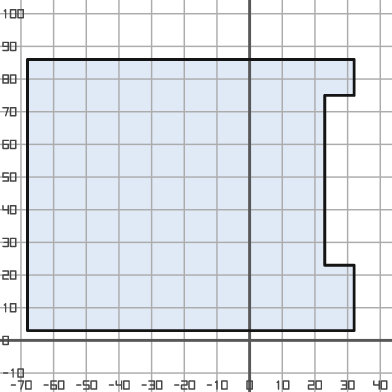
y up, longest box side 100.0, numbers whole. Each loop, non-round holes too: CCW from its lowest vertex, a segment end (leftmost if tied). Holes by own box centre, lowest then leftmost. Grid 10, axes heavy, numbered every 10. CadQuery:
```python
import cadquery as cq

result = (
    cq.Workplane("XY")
    .moveTo(-68.0, 3.0)
    .lineTo(32.0, 3.0)
    .lineTo(32.0, 23.0)
    .lineTo(23.0, 23.0)
    .lineTo(23.0, 75.0)
    .lineTo(32.0, 75.0)
    .lineTo(32.0, 86.0)
    .lineTo(-68.0, 86.0)
    .close()
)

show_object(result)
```